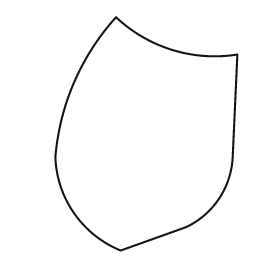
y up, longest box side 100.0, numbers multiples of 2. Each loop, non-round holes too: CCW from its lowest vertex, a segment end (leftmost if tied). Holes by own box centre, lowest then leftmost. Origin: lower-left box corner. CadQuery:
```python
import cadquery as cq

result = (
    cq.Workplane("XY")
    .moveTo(28.0, 0.0)
    .lineTo(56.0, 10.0)
    .threePointArc((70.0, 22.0), (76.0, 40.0))
    .lineTo(78.0, 84.0)
    .threePointArc((50.0, 86.0), (26.0, 100.0))
    .threePointArc((8.0, 72.0), (0.0, 40.0))
    .threePointArc((8.0, 16.0), (28.0, 0.0))
    .close()
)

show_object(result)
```